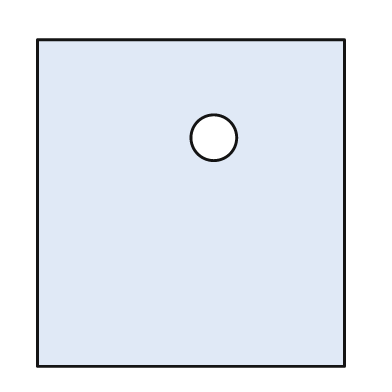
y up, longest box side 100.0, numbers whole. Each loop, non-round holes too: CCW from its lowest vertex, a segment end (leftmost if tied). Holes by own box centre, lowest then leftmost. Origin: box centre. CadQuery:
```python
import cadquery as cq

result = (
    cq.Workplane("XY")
    .moveTo(-47.0, -50.0)
    .lineTo(47.0, -50.0)
    .lineTo(47.0, 50.0)
    .lineTo(-47.0, 50.0)
    .close()
    .moveTo(7.0, 20.0)
    .circle(7.0)
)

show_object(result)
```